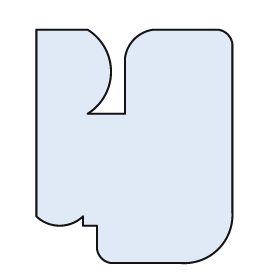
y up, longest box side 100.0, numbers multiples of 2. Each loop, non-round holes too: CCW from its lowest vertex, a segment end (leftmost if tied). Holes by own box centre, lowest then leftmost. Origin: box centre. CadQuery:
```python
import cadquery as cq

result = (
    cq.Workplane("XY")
    .moveTo(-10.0, -50.0)
    .lineTo(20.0, -50.0)
    .threePointArc((36.0, -44.0), (42.0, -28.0))
    .lineTo(42.0, 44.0)
    .threePointArc((40.0, 48.0), (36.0, 50.0))
    .lineTo(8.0, 50.0)
    .threePointArc((0.0, 46.0), (-4.0, 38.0))
    .lineTo(-4.0, 14.0)
    .lineTo(-20.0, 14.0)
    .threePointArc((-10.0, 32.0), (-20.0, 50.0))
    .lineTo(-42.0, 50.0)
    .lineTo(-42.0, -30.0)
    .threePointArc((-32.0, -34.0), (-22.0, -30.0))
    .lineTo(-22.0, -34.0)
    .lineTo(-16.0, -34.0)
    .lineTo(-16.0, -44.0)
    .threePointArc((-14.0, -48.0), (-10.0, -50.0))
    .close()
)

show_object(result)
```